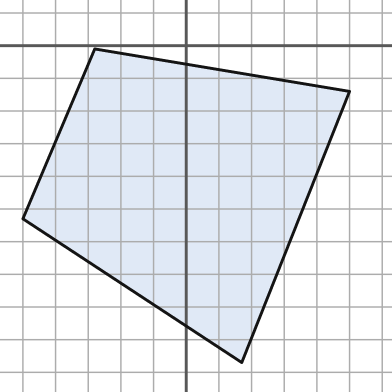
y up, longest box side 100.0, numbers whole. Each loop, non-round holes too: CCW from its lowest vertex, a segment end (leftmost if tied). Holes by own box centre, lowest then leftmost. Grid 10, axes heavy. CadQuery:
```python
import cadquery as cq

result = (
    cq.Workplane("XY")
    .moveTo(17.0, -97.0)
    .lineTo(50.0, -14.0)
    .lineTo(-28.0, -1.0)
    .lineTo(-50.0, -53.0)
    .close()
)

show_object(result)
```